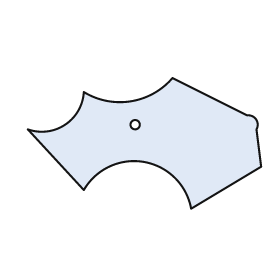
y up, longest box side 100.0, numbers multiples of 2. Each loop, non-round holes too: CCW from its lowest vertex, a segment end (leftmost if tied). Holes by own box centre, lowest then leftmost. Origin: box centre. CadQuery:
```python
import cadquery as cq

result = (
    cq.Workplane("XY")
    .moveTo(20.0, -28.0)
    .lineTo(50.0, -10.0)
    .lineTo(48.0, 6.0)
    .threePointArc((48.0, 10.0), (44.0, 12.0))
    .lineTo(12.0, 28.0)
    .threePointArc((-6.0, 18.0), (-26.0, 22.0))
    .threePointArc((-34.0, 8.0), (-50.0, 6.0))
    .lineTo(-26.0, -20.0)
    .threePointArc((0.0, -8.0), (20.0, -28.0))
    .close()
    .moveTo(-4.0, 8.0)
    .circle(2.0)
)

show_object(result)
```